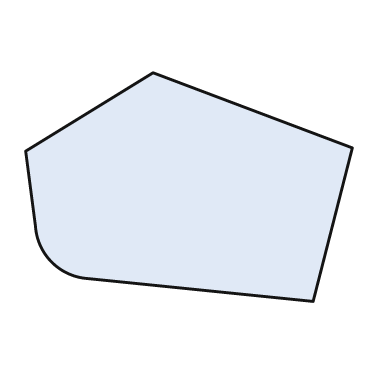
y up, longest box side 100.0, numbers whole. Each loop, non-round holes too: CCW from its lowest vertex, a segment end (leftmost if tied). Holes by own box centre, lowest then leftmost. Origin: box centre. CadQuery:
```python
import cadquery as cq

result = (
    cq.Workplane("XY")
    .moveTo(38.0, -35.0)
    .lineTo(50.0, 12.0)
    .lineTo(-11.0, 35.0)
    .lineTo(-50.0, 11.0)
    .lineTo(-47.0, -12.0)
    .threePointArc((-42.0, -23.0), (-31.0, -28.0))
    .close()
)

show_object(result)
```